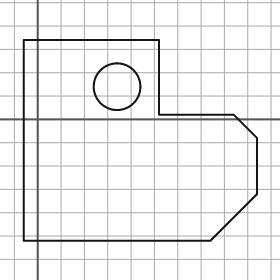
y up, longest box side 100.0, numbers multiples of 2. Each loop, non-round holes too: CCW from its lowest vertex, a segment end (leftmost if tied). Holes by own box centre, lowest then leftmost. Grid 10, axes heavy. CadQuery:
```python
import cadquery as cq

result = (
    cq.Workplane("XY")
    .moveTo(-6.0, -52.0)
    .lineTo(74.0, -52.0)
    .lineTo(94.0, -32.0)
    .lineTo(94.0, -8.0)
    .lineTo(84.0, 2.0)
    .lineTo(52.0, 2.0)
    .lineTo(52.0, 34.0)
    .lineTo(-6.0, 34.0)
    .close()
    .moveTo(34.0, 14.0)
    .circle(10.0)
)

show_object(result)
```